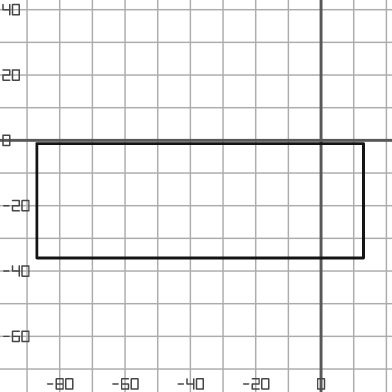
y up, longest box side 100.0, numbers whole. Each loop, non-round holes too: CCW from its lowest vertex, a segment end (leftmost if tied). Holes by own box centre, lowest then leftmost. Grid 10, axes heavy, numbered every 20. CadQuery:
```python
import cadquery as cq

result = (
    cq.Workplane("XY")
    .moveTo(-87.0, -36.0)
    .lineTo(13.0, -36.0)
    .lineTo(13.0, -1.0)
    .lineTo(-87.0, -1.0)
    .close()
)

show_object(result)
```